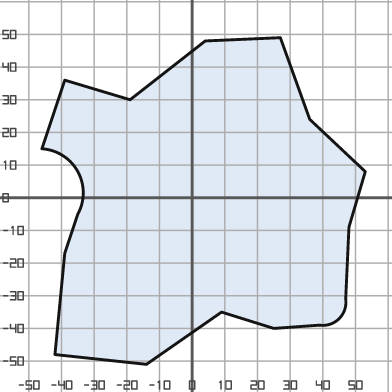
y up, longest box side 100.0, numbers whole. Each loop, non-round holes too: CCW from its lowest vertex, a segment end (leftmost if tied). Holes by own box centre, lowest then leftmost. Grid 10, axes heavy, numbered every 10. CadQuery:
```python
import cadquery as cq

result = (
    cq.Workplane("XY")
    .moveTo(-14.0, -51.0)
    .lineTo(9.0, -35.0)
    .lineTo(25.0, -40.0)
    .lineTo(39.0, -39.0)
    .threePointArc((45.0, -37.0), (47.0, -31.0))
    .lineTo(48.0, -9.0)
    .lineTo(53.0, 8.0)
    .lineTo(36.0, 24.0)
    .lineTo(27.0, 49.0)
    .lineTo(4.0, 48.0)
    .lineTo(-19.0, 30.0)
    .lineTo(-39.0, 36.0)
    .lineTo(-46.0, 15.0)
    .threePointArc((-35.0, 8.0), (-35.0, -5.0))
    .lineTo(-39.0, -17.0)
    .lineTo(-42.0, -48.0)
    .close()
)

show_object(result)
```